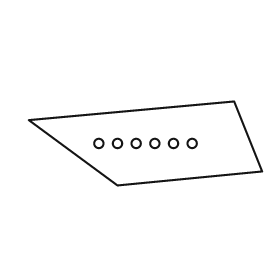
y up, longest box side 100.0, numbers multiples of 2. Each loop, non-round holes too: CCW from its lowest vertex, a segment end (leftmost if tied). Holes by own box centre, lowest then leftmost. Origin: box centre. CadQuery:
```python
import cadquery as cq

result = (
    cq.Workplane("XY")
    .moveTo(-12.0, -18.0)
    .lineTo(50.0, -12.0)
    .lineTo(38.0, 18.0)
    .lineTo(-50.0, 10.0)
    .close()
    .moveTo(-20.0, 0.0)
    .circle(2.0)
    .moveTo(-12.0, 0.0)
    .circle(2.0)
    .moveTo(-4.0, 0.0)
    .circle(2.0)
    .moveTo(4.0, 0.0)
    .circle(2.0)
    .moveTo(12.0, 0.0)
    .circle(2.0)
    .moveTo(20.0, 0.0)
    .circle(2.0)
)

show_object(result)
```